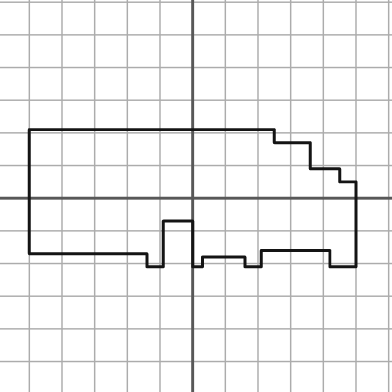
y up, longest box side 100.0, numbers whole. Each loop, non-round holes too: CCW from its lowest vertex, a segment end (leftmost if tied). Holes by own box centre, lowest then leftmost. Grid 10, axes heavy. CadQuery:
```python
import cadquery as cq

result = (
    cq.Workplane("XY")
    .moveTo(-14.0, -21.0)
    .lineTo(-9.0, -21.0)
    .lineTo(-9.0, -7.0)
    .lineTo(0.0, -7.0)
    .lineTo(0.0, -21.0)
    .lineTo(3.0, -21.0)
    .lineTo(3.0, -18.0)
    .lineTo(16.0, -18.0)
    .lineTo(16.0, -21.0)
    .lineTo(21.0, -21.0)
    .lineTo(21.0, -16.0)
    .lineTo(42.0, -16.0)
    .lineTo(42.0, -21.0)
    .lineTo(50.0, -21.0)
    .lineTo(50.0, 5.0)
    .lineTo(45.0, 5.0)
    .lineTo(45.0, 9.0)
    .lineTo(36.0, 9.0)
    .lineTo(36.0, 17.0)
    .lineTo(25.0, 17.0)
    .lineTo(25.0, 21.0)
    .lineTo(-50.0, 21.0)
    .lineTo(-50.0, -17.0)
    .lineTo(-14.0, -17.0)
    .close()
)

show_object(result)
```